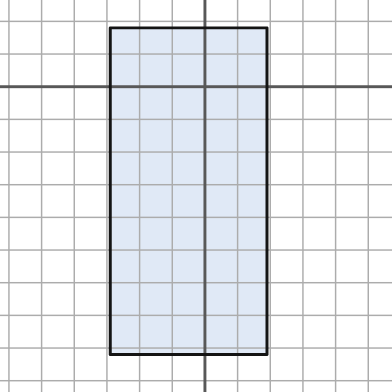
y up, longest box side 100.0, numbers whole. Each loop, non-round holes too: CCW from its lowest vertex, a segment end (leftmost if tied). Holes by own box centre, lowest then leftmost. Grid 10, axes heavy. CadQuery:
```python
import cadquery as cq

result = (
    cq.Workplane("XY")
    .moveTo(-29.0, -82.0)
    .lineTo(19.0, -82.0)
    .lineTo(19.0, 18.0)
    .lineTo(-29.0, 18.0)
    .close()
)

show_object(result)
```